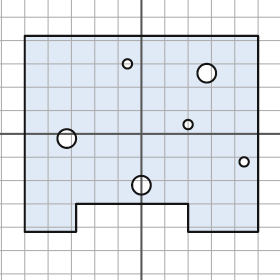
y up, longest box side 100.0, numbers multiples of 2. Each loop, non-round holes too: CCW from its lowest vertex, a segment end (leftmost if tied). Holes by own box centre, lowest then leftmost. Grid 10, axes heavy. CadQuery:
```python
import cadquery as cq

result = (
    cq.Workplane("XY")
    .moveTo(-50.0, -42.0)
    .lineTo(-28.0, -42.0)
    .lineTo(-28.0, -30.0)
    .lineTo(20.0, -30.0)
    .lineTo(20.0, -42.0)
    .lineTo(50.0, -42.0)
    .lineTo(50.0, 42.0)
    .lineTo(-50.0, 42.0)
    .close()
    .moveTo(0.0, -22.0)
    .circle(4.0)
    .moveTo(44.0, -12.0)
    .circle(2.0)
    .moveTo(-32.0, -2.0)
    .circle(4.0)
    .moveTo(20.0, 4.0)
    .circle(2.0)
    .moveTo(28.0, 26.0)
    .circle(4.0)
    .moveTo(-6.0, 30.0)
    .circle(2.0)
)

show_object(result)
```